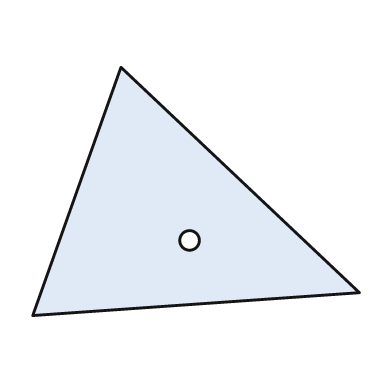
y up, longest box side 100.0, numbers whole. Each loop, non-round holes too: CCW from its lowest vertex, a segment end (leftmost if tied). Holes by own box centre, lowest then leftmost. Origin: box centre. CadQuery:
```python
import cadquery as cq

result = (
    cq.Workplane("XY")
    .moveTo(-50.0, -38.0)
    .lineTo(50.0, -31.0)
    .lineTo(-23.0, 38.0)
    .close()
    .moveTo(-2.0, -15.0)
    .circle(3.0)
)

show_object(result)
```